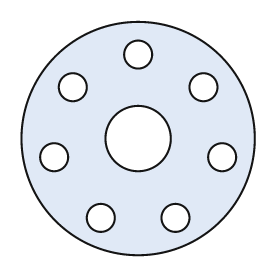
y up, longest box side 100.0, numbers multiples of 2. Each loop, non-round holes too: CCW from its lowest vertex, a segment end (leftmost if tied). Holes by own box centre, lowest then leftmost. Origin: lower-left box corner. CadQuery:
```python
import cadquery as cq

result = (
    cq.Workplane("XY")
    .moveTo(50.0, 50.0)
    .circle(50.0)
    .moveTo(34.0, 16.0)
    .circle(6.0)
    .moveTo(66.0, 16.0)
    .circle(6.0)
    .moveTo(14.0, 42.0)
    .circle(6.0)
    .moveTo(86.0, 42.0)
    .circle(6.0)
    .moveTo(50.0, 50.0)
    .circle(14.0)
    .moveTo(22.0, 72.0)
    .circle(6.0)
    .moveTo(78.0, 72.0)
    .circle(6.0)
    .moveTo(50.0, 86.0)
    .circle(6.0)
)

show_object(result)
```